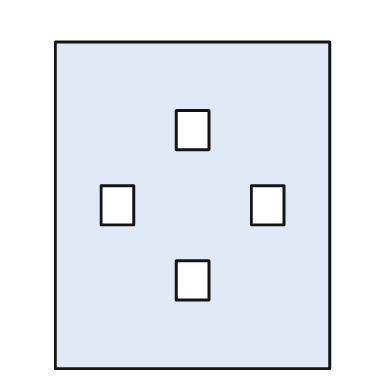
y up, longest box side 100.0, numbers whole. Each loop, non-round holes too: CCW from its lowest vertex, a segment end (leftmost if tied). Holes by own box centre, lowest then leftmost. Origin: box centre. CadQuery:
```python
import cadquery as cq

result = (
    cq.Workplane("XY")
    .moveTo(-42.0, -50.0)
    .lineTo(42.0, -50.0)
    .lineTo(42.0, 50.0)
    .lineTo(-42.0, 50.0)
    .close()
    .moveTo(-5.0, -29.0)
    .lineTo(5.0, -29.0)
    .lineTo(5.0, -17.0)
    .lineTo(-5.0, -17.0)
    .close()
    .moveTo(-28.0, -6.0)
    .lineTo(-18.0, -6.0)
    .lineTo(-18.0, 6.0)
    .lineTo(-28.0, 6.0)
    .close()
    .moveTo(18.0, -6.0)
    .lineTo(28.0, -6.0)
    .lineTo(28.0, 6.0)
    .lineTo(18.0, 6.0)
    .close()
    .moveTo(-5.0, 17.0)
    .lineTo(5.0, 17.0)
    .lineTo(5.0, 29.0)
    .lineTo(-5.0, 29.0)
    .close()
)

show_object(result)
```